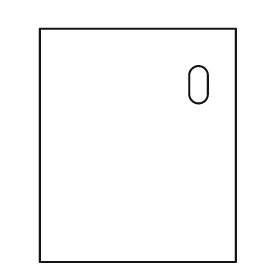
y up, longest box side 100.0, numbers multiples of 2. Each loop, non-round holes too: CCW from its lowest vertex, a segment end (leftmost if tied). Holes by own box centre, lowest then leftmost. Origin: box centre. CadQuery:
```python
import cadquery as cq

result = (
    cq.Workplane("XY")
    .moveTo(-42.0, -50.0)
    .lineTo(42.0, -50.0)
    .lineTo(42.0, 50.0)
    .lineTo(-42.0, 50.0)
    .close()
    .moveTo(22.0, 22.0)
    .threePointArc((26.0, 18.0), (30.0, 22.0))
    .lineTo(30.0, 30.0)
    .threePointArc((26.0, 34.0), (22.0, 30.0))
    .close()
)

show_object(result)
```